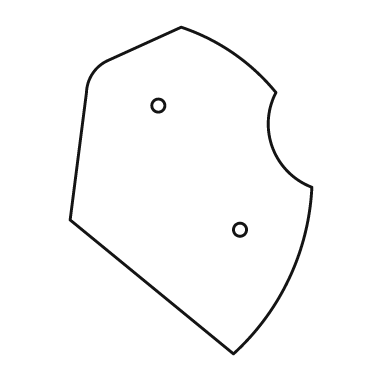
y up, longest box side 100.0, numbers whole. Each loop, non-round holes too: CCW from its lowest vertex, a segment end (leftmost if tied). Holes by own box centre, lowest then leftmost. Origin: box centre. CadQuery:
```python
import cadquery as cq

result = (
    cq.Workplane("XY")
    .moveTo(13.0, -50.0)
    .threePointArc((30.0, -27.0), (37.0, 1.0))
    .threePointArc((25.0, 13.0), (26.0, 30.0))
    .threePointArc((13.0, 42.0), (-3.0, 50.0))
    .lineTo(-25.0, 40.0)
    .threePointArc((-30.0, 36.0), (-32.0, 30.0))
    .lineTo(-37.0, -9.0)
    .close()
    .moveTo(15.0, -12.0)
    .circle(2.0)
    .moveTo(-10.0, 26.0)
    .circle(2.0)
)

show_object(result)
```